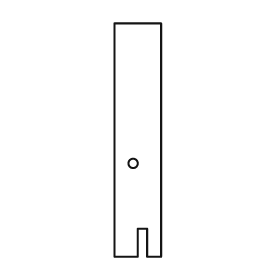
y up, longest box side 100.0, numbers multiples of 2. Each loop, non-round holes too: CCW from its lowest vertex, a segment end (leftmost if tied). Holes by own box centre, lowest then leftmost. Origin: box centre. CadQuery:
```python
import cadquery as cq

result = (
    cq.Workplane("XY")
    .moveTo(-10.0, -50.0)
    .lineTo(0.0, -50.0)
    .lineTo(0.0, -38.0)
    .lineTo(4.0, -38.0)
    .lineTo(4.0, -50.0)
    .lineTo(10.0, -50.0)
    .lineTo(10.0, 50.0)
    .lineTo(-10.0, 50.0)
    .close()
    .moveTo(-2.0, -10.0)
    .circle(2.0)
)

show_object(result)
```